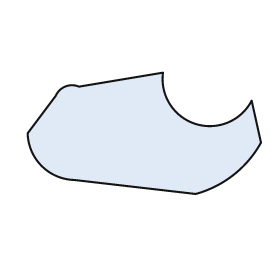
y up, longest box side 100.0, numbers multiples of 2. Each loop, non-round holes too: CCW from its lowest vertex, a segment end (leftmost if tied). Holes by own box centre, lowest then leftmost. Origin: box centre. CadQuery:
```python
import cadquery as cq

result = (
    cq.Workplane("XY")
    .moveTo(22.0, -26.0)
    .threePointArc((38.0, -18.0), (50.0, -4.0))
    .lineTo(46.0, 14.0)
    .threePointArc((22.0, 4.0), (8.0, 26.0))
    .lineTo(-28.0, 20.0)
    .threePointArc((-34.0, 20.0), (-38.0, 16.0))
    .lineTo(-50.0, 0.0)
    .threePointArc((-44.0, -14.0), (-30.0, -20.0))
    .close()
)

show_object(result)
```